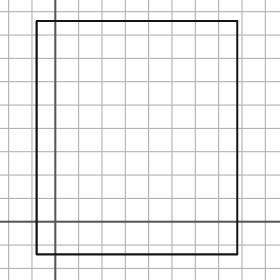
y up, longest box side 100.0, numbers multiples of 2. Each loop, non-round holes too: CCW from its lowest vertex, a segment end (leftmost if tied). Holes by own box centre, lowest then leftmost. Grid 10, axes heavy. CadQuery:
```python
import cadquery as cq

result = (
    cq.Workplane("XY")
    .moveTo(-8.0, -14.0)
    .lineTo(78.0, -14.0)
    .lineTo(78.0, 86.0)
    .lineTo(-8.0, 86.0)
    .close()
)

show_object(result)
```